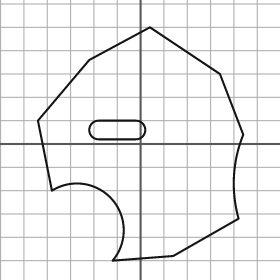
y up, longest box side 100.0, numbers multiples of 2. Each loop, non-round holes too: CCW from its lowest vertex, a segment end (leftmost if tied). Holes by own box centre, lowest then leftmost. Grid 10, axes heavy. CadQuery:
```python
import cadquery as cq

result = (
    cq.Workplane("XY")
    .moveTo(-12.0, -50.0)
    .lineTo(14.0, -48.0)
    .lineTo(42.0, -32.0)
    .threePointArc((40.0, -14.0), (44.0, 4.0))
    .lineTo(34.0, 30.0)
    .lineTo(4.0, 50.0)
    .lineTo(-22.0, 36.0)
    .lineTo(-44.0, 10.0)
    .lineTo(-38.0, -20.0)
    .threePointArc((-12.0, -24.0), (-12.0, -50.0))
    .close()
    .moveTo(-18.0, 2.0)
    .lineTo(-2.0, 2.0)
    .threePointArc((2.0, 6.0), (-2.0, 10.0))
    .lineTo(-18.0, 10.0)
    .threePointArc((-22.0, 6.0), (-18.0, 2.0))
    .close()
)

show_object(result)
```